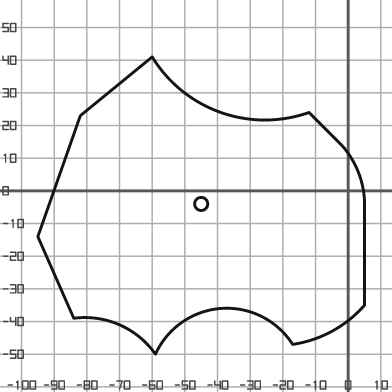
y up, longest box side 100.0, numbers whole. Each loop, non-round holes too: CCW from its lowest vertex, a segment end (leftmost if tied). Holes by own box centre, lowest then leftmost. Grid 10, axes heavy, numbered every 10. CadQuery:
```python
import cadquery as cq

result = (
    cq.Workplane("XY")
    .moveTo(-59.0, -50.0)
    .threePointArc((-39.0, -36.0), (-17.0, -47.0))
    .threePointArc((-5.0, -43.0), (5.0, -35.0))
    .lineTo(5.0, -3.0)
    .threePointArc((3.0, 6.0), (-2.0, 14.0))
    .lineTo(-12.0, 24.0)
    .threePointArc((-39.0, 24.0), (-60.0, 41.0))
    .lineTo(-82.0, 23.0)
    .lineTo(-95.0, -14.0)
    .lineTo(-84.0, -39.0)
    .threePointArc((-70.0, -41.0), (-59.0, -50.0))
    .close()
    .moveTo(-45.0, -4.0)
    .circle(2.0)
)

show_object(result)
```